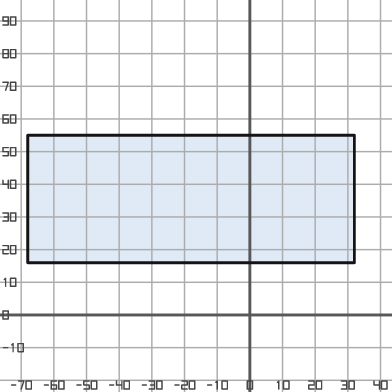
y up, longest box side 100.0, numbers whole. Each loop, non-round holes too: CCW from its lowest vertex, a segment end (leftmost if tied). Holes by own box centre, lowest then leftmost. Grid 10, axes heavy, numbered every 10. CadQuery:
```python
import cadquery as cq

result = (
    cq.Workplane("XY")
    .moveTo(-68.0, 16.0)
    .lineTo(32.0, 16.0)
    .lineTo(32.0, 55.0)
    .lineTo(-68.0, 55.0)
    .close()
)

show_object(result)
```